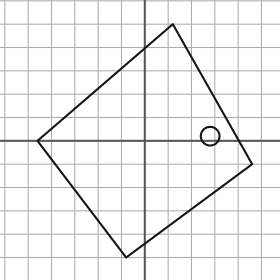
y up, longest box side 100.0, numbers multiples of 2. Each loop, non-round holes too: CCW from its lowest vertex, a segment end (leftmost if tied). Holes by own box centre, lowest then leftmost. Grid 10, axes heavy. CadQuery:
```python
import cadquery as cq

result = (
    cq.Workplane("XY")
    .moveTo(-8.0, -50.0)
    .lineTo(46.0, -10.0)
    .lineTo(12.0, 50.0)
    .lineTo(-46.0, 0.0)
    .close()
    .moveTo(28.0, 2.0)
    .circle(4.0)
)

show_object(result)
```